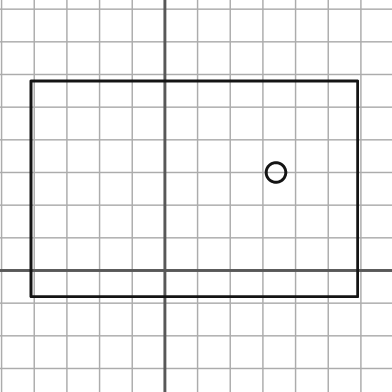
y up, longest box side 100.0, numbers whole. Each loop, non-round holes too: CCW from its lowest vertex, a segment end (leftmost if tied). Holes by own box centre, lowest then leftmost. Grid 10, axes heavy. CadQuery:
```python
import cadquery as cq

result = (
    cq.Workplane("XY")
    .moveTo(-41.0, -8.0)
    .lineTo(59.0, -8.0)
    .lineTo(59.0, 58.0)
    .lineTo(-41.0, 58.0)
    .close()
    .moveTo(34.0, 30.0)
    .circle(3.0)
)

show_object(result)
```